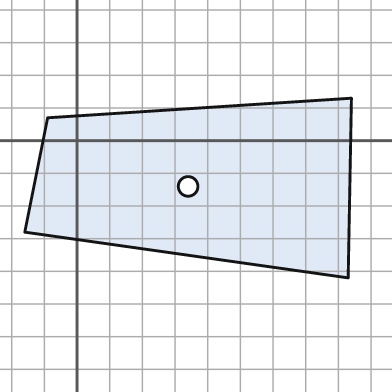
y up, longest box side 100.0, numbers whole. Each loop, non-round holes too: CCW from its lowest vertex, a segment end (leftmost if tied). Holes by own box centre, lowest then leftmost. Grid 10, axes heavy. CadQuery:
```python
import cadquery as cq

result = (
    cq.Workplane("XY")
    .moveTo(83.0, -42.0)
    .lineTo(84.0, 13.0)
    .lineTo(-9.0, 7.0)
    .lineTo(-16.0, -28.0)
    .close()
    .moveTo(34.0, -14.0)
    .circle(3.0)
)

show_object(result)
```